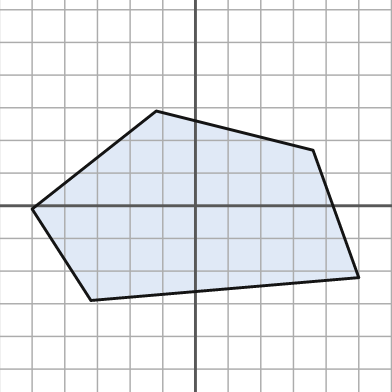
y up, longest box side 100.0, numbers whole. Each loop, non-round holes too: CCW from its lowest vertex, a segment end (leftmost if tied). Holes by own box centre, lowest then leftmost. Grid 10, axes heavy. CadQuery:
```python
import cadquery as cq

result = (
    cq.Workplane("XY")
    .moveTo(-32.0, -29.0)
    .lineTo(50.0, -22.0)
    .lineTo(36.0, 17.0)
    .lineTo(-12.0, 29.0)
    .lineTo(-50.0, -1.0)
    .close()
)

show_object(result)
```